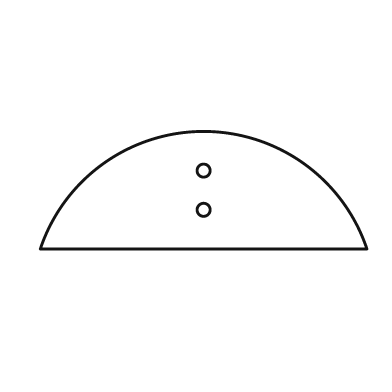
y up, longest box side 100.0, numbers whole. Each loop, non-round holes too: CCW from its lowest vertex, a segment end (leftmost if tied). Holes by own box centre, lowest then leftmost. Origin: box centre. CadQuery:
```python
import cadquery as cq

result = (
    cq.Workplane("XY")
    .moveTo(-50.0, -18.0)
    .lineTo(50.0, -18.0)
    .threePointArc((0.0, 18.0), (-50.0, -18.0))
    .close()
    .moveTo(0.0, -6.0)
    .circle(2.0)
    .moveTo(0.0, 6.0)
    .circle(2.0)
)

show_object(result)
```